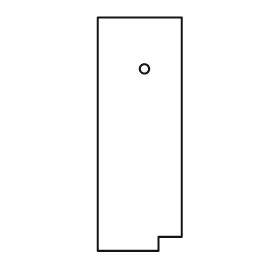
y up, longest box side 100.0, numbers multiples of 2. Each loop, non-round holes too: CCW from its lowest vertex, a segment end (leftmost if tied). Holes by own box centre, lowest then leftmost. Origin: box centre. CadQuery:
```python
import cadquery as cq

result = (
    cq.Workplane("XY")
    .moveTo(-18.0, -50.0)
    .lineTo(8.0, -50.0)
    .lineTo(8.0, -44.0)
    .lineTo(18.0, -44.0)
    .lineTo(18.0, 50.0)
    .lineTo(-18.0, 50.0)
    .close()
    .moveTo(2.0, 28.0)
    .circle(2.0)
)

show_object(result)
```